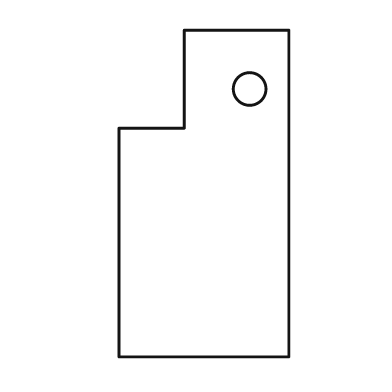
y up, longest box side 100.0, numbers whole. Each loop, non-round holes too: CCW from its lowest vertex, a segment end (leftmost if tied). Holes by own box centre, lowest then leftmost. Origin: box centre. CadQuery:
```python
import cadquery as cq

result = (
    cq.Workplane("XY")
    .moveTo(-26.0, -50.0)
    .lineTo(26.0, -50.0)
    .lineTo(26.0, 50.0)
    .lineTo(-6.0, 50.0)
    .lineTo(-6.0, 20.0)
    .lineTo(-26.0, 20.0)
    .close()
    .moveTo(14.0, 32.0)
    .circle(5.0)
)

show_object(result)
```